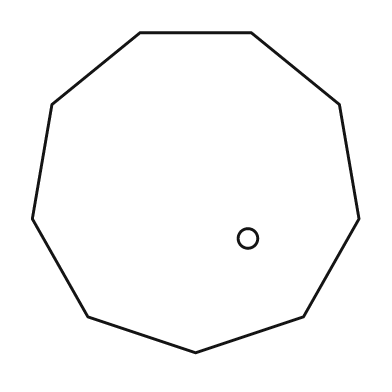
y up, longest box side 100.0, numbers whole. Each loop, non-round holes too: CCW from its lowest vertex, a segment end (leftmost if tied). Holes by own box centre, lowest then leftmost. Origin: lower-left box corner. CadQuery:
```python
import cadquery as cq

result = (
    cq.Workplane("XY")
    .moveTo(50.0, 0.0)
    .lineTo(83.0, 11.0)
    .lineTo(100.0, 41.0)
    .lineTo(94.0, 76.0)
    .lineTo(67.0, 98.0)
    .lineTo(33.0, 98.0)
    .lineTo(6.0, 76.0)
    .lineTo(0.0, 41.0)
    .lineTo(17.0, 11.0)
    .close()
    .moveTo(66.0, 35.0)
    .circle(3.0)
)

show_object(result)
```